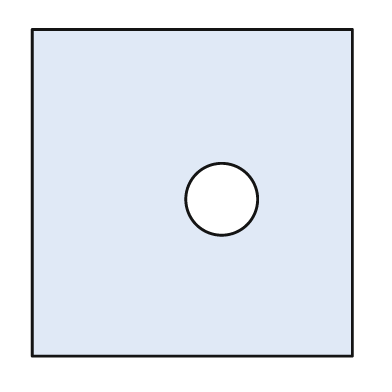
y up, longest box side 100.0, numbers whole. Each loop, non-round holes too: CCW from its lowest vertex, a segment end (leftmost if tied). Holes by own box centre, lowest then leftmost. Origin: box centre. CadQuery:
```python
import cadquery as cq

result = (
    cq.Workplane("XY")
    .moveTo(-49.0, -50.0)
    .lineTo(49.0, -50.0)
    .lineTo(49.0, 50.0)
    .lineTo(-49.0, 50.0)
    .close()
    .moveTo(9.0, -2.0)
    .circle(11.0)
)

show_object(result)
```